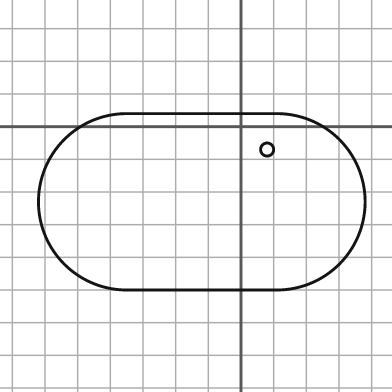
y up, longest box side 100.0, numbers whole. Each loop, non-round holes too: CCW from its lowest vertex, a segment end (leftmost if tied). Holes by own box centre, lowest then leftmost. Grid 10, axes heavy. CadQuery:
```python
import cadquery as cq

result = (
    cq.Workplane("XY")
    .moveTo(-35.0, -50.0)
    .lineTo(11.0, -50.0)
    .threePointArc((38.0, -23.0), (11.0, 4.0))
    .lineTo(-35.0, 4.0)
    .threePointArc((-62.0, -23.0), (-35.0, -50.0))
    .close()
    .moveTo(8.0, -7.0)
    .circle(2.0)
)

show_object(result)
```